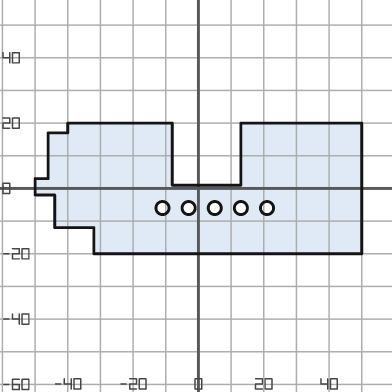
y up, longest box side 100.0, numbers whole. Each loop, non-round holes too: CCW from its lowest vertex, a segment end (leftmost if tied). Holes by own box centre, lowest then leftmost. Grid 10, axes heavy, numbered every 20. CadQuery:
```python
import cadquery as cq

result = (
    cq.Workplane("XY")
    .moveTo(-32.0, -20.0)
    .lineTo(50.0, -20.0)
    .lineTo(50.0, 20.0)
    .lineTo(13.0, 20.0)
    .lineTo(13.0, 1.0)
    .lineTo(-8.0, 1.0)
    .lineTo(-8.0, 20.0)
    .lineTo(-40.0, 20.0)
    .lineTo(-40.0, 17.0)
    .lineTo(-46.0, 17.0)
    .lineTo(-46.0, 3.0)
    .lineTo(-50.0, 3.0)
    .lineTo(-50.0, -2.0)
    .lineTo(-44.0, -2.0)
    .lineTo(-44.0, -12.0)
    .lineTo(-32.0, -12.0)
    .close()
    .moveTo(-11.0, -6.0)
    .circle(2.0)
    .moveTo(-3.0, -6.0)
    .circle(2.0)
    .moveTo(5.0, -6.0)
    .circle(2.0)
    .moveTo(13.0, -6.0)
    .circle(2.0)
    .moveTo(21.0, -6.0)
    .circle(2.0)
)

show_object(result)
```